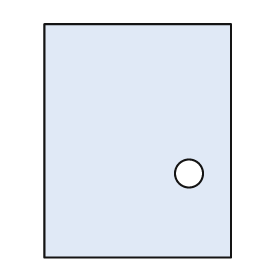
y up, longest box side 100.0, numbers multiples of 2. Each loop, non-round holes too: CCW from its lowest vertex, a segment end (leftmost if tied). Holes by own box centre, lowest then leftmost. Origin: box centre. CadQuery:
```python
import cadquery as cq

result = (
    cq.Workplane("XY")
    .moveTo(-40.0, -50.0)
    .lineTo(40.0, -50.0)
    .lineTo(40.0, 50.0)
    .lineTo(-40.0, 50.0)
    .close()
    .moveTo(22.0, -14.0)
    .circle(6.0)
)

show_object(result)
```